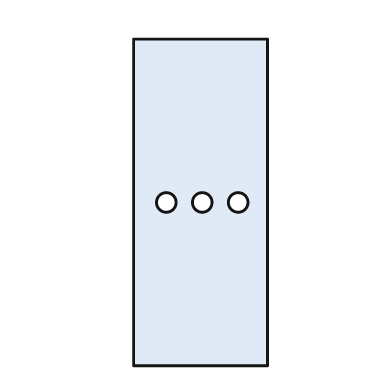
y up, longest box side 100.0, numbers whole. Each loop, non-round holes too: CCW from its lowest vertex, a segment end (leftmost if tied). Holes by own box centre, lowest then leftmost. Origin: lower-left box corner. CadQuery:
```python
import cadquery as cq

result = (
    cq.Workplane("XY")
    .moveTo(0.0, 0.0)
    .lineTo(41.0, 0.0)
    .lineTo(41.0, 100.0)
    .lineTo(0.0, 100.0)
    .close()
    .moveTo(10.0, 50.0)
    .circle(3.0)
    .moveTo(21.0, 50.0)
    .circle(3.0)
    .moveTo(32.0, 50.0)
    .circle(3.0)
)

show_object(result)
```